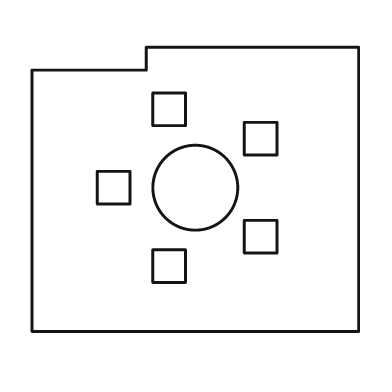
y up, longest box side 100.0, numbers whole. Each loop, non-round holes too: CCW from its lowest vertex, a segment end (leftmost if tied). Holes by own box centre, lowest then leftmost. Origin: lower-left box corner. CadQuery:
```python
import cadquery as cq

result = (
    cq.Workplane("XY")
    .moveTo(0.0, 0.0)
    .lineTo(100.0, 0.0)
    .lineTo(100.0, 87.0)
    .lineTo(35.0, 87.0)
    .lineTo(35.0, 80.0)
    .lineTo(0.0, 80.0)
    .close()
    .moveTo(37.0, 15.0)
    .lineTo(47.0, 15.0)
    .lineTo(47.0, 25.0)
    .lineTo(37.0, 25.0)
    .close()
    .moveTo(65.0, 24.0)
    .lineTo(75.0, 24.0)
    .lineTo(75.0, 34.0)
    .lineTo(65.0, 34.0)
    .close()
    .moveTo(20.0, 39.0)
    .lineTo(30.0, 39.0)
    .lineTo(30.0, 49.0)
    .lineTo(20.0, 49.0)
    .close()
    .moveTo(50.0, 44.0)
    .circle(13.0)
    .moveTo(65.0, 54.0)
    .lineTo(75.0, 54.0)
    .lineTo(75.0, 64.0)
    .lineTo(65.0, 64.0)
    .close()
    .moveTo(37.0, 63.0)
    .lineTo(47.0, 63.0)
    .lineTo(47.0, 73.0)
    .lineTo(37.0, 73.0)
    .close()
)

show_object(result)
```